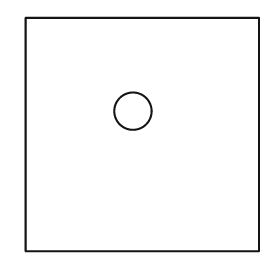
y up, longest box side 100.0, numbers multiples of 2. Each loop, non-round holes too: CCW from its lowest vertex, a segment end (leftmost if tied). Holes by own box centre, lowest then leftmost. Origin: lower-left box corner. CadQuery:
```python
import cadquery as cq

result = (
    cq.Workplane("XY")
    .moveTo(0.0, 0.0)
    .lineTo(100.0, 0.0)
    .lineTo(100.0, 100.0)
    .lineTo(0.0, 100.0)
    .close()
    .moveTo(46.0, 60.0)
    .circle(8.0)
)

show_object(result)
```